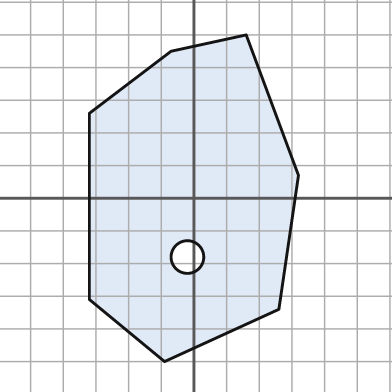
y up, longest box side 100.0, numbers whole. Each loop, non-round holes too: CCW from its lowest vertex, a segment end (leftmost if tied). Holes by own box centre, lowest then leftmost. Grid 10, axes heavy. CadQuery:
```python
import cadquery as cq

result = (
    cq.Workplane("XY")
    .moveTo(-9.0, -50.0)
    .lineTo(26.0, -34.0)
    .lineTo(32.0, 7.0)
    .lineTo(16.0, 50.0)
    .lineTo(-7.0, 45.0)
    .lineTo(-32.0, 26.0)
    .lineTo(-32.0, -31.0)
    .close()
    .moveTo(-2.0, -18.0)
    .circle(5.0)
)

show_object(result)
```